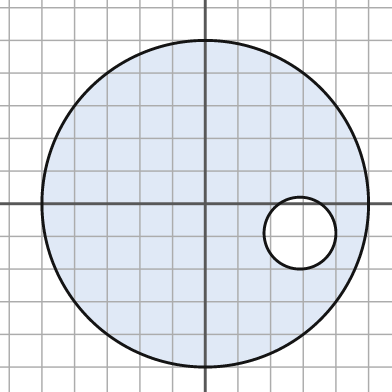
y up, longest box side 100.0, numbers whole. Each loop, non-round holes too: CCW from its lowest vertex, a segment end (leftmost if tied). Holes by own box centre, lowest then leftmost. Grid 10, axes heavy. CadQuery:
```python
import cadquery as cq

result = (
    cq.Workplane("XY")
    .moveTo(0.0, 0.0)
    .circle(50.0)
    .moveTo(29.0, -9.0)
    .circle(11.0)
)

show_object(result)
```